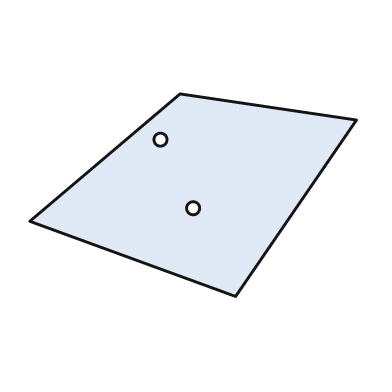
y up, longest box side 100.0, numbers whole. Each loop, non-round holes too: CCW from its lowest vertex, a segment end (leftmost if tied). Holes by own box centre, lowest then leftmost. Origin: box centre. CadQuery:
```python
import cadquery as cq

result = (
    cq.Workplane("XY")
    .moveTo(13.0, -31.0)
    .lineTo(50.0, 23.0)
    .lineTo(-4.0, 31.0)
    .lineTo(-50.0, -8.0)
    .close()
    .moveTo(0.0, -4.0)
    .circle(2.0)
    .moveTo(-10.0, 17.0)
    .circle(2.0)
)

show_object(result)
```